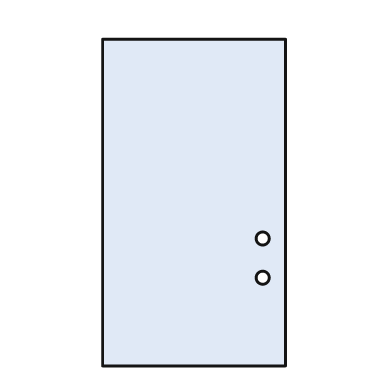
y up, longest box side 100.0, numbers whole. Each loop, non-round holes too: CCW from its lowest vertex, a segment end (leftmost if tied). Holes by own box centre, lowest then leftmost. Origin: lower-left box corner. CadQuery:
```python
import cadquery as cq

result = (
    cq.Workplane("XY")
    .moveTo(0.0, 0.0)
    .lineTo(56.0, 0.0)
    .lineTo(56.0, 100.0)
    .lineTo(0.0, 100.0)
    .close()
    .moveTo(49.0, 27.0)
    .circle(2.0)
    .moveTo(49.0, 39.0)
    .circle(2.0)
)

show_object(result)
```